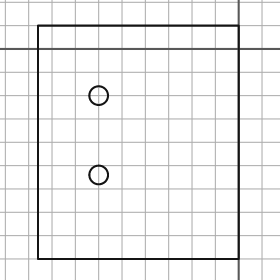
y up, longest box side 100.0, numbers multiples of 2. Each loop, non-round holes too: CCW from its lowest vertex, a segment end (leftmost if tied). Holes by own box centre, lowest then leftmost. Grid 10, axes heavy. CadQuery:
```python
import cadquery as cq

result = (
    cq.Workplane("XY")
    .moveTo(-86.0, -90.0)
    .lineTo(0.0, -90.0)
    .lineTo(0.0, 10.0)
    .lineTo(-86.0, 10.0)
    .close()
    .moveTo(-60.0, -54.0)
    .circle(4.0)
    .moveTo(-60.0, -20.0)
    .circle(4.0)
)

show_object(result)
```